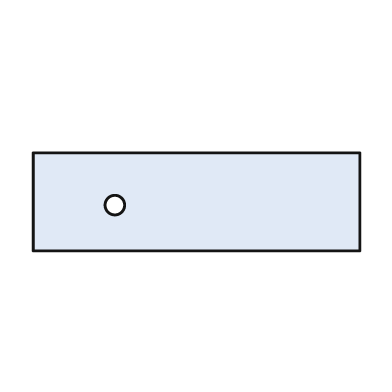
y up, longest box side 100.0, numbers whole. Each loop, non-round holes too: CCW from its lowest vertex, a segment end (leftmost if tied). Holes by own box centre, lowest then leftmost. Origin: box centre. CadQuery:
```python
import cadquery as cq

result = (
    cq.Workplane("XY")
    .moveTo(-50.0, -15.0)
    .lineTo(50.0, -15.0)
    .lineTo(50.0, 15.0)
    .lineTo(-50.0, 15.0)
    .close()
    .moveTo(-25.0, -1.0)
    .circle(3.0)
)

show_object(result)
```